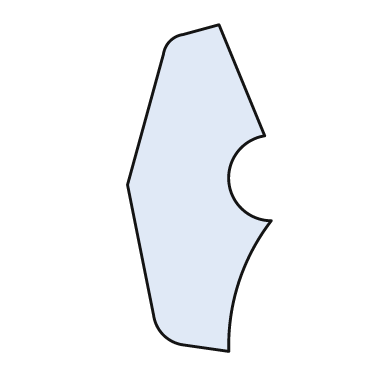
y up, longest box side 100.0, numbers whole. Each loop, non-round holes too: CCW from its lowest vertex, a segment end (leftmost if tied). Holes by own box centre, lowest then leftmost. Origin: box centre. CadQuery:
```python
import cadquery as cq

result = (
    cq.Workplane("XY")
    .moveTo(9.0, -50.0)
    .threePointArc((12.0, -29.0), (22.0, -10.0))
    .threePointArc((9.0, 2.0), (20.0, 16.0))
    .lineTo(6.0, 50.0)
    .lineTo(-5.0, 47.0)
    .threePointArc((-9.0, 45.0), (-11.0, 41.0))
    .lineTo(-22.0, 1.0)
    .lineTo(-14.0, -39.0)
    .threePointArc((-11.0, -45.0), (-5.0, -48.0))
    .close()
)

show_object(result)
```